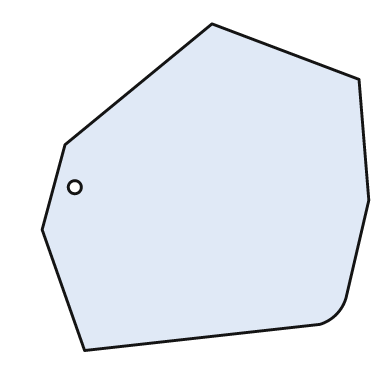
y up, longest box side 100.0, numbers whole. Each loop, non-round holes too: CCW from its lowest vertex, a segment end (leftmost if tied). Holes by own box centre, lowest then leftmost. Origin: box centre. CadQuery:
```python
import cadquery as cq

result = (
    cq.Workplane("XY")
    .moveTo(-37.0, -50.0)
    .lineTo(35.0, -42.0)
    .threePointArc((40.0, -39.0), (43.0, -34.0))
    .lineTo(50.0, -4.0)
    .lineTo(47.0, 33.0)
    .lineTo(2.0, 50.0)
    .lineTo(-43.0, 13.0)
    .lineTo(-50.0, -13.0)
    .close()
    .moveTo(-40.0, 0.0)
    .circle(2.0)
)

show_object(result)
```